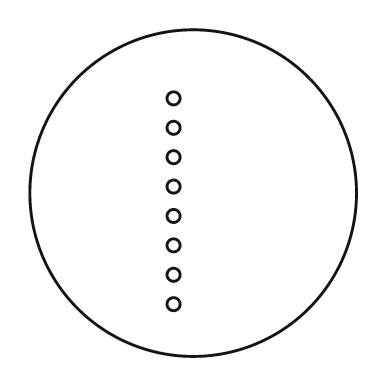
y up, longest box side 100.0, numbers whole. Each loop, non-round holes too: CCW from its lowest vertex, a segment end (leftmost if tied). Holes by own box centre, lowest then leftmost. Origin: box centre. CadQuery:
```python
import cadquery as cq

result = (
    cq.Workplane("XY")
    .moveTo(0.0, 0.0)
    .circle(50.0)
    .moveTo(-6.0, -34.0)
    .circle(2.0)
    .moveTo(-6.0, -25.0)
    .circle(2.0)
    .moveTo(-6.0, -16.0)
    .circle(2.0)
    .moveTo(-6.0, -7.0)
    .circle(2.0)
    .moveTo(-6.0, 2.0)
    .circle(2.0)
    .moveTo(-6.0, 11.0)
    .circle(2.0)
    .moveTo(-6.0, 20.0)
    .circle(2.0)
    .moveTo(-6.0, 29.0)
    .circle(2.0)
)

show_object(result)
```